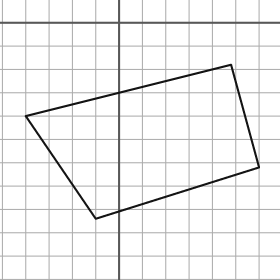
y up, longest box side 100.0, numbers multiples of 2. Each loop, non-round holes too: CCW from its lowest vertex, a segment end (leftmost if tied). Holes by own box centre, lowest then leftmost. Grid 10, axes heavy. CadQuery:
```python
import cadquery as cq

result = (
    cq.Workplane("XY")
    .moveTo(-10.0, -84.0)
    .lineTo(60.0, -62.0)
    .lineTo(48.0, -18.0)
    .lineTo(-40.0, -40.0)
    .close()
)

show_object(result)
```